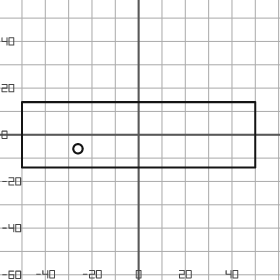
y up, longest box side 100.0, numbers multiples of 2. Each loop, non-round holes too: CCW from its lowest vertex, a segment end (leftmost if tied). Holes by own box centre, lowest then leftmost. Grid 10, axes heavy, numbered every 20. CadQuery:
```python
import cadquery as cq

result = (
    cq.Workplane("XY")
    .moveTo(-50.0, -14.0)
    .lineTo(50.0, -14.0)
    .lineTo(50.0, 14.0)
    .lineTo(-50.0, 14.0)
    .close()
    .moveTo(-26.0, -6.0)
    .circle(2.0)
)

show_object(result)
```